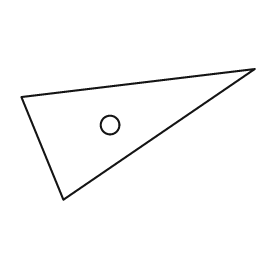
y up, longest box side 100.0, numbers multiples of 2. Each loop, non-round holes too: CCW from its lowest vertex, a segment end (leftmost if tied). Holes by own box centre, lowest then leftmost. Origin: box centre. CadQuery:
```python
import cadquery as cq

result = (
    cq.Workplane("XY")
    .moveTo(-32.0, -28.0)
    .lineTo(50.0, 28.0)
    .lineTo(-50.0, 16.0)
    .close()
    .moveTo(-12.0, 4.0)
    .circle(4.0)
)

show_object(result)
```